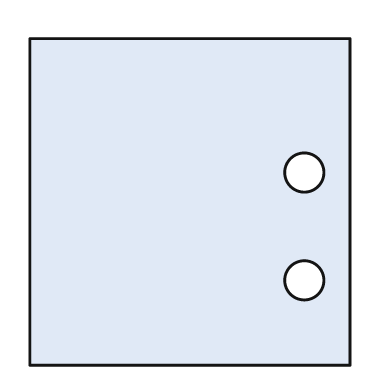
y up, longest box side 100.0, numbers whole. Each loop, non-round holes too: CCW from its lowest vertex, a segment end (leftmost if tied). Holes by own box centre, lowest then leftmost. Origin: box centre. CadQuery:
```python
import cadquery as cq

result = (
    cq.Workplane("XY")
    .moveTo(-49.0, -50.0)
    .lineTo(49.0, -50.0)
    .lineTo(49.0, 50.0)
    .lineTo(-49.0, 50.0)
    .close()
    .moveTo(35.0, -24.0)
    .circle(6.0)
    .moveTo(35.0, 9.0)
    .circle(6.0)
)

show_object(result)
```